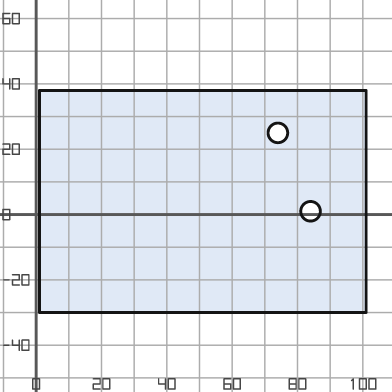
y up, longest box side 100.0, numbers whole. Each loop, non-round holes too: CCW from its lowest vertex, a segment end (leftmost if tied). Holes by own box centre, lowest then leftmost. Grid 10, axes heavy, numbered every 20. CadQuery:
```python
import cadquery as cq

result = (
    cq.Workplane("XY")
    .moveTo(1.0, -30.0)
    .lineTo(101.0, -30.0)
    .lineTo(101.0, 38.0)
    .lineTo(1.0, 38.0)
    .close()
    .moveTo(84.0, 1.0)
    .circle(3.0)
    .moveTo(74.0, 25.0)
    .circle(3.0)
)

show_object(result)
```